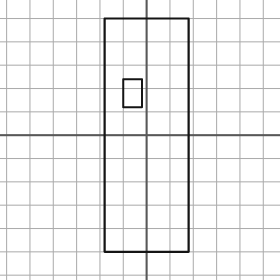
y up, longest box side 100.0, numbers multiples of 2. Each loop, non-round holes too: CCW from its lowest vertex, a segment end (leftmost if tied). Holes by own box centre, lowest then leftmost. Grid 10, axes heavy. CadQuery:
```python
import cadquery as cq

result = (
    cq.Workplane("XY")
    .moveTo(-18.0, -50.0)
    .lineTo(18.0, -50.0)
    .lineTo(18.0, 50.0)
    .lineTo(-18.0, 50.0)
    .close()
    .moveTo(-10.0, 12.0)
    .lineTo(-2.0, 12.0)
    .lineTo(-2.0, 24.0)
    .lineTo(-10.0, 24.0)
    .close()
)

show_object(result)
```